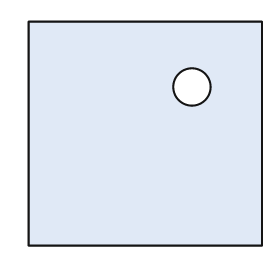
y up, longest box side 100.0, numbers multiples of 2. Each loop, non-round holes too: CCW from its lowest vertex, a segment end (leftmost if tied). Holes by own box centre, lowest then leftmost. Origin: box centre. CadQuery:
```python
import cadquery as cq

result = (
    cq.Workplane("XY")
    .moveTo(-50.0, -48.0)
    .lineTo(50.0, -48.0)
    .lineTo(50.0, 48.0)
    .lineTo(-50.0, 48.0)
    .close()
    .moveTo(20.0, 20.0)
    .circle(8.0)
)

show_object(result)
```